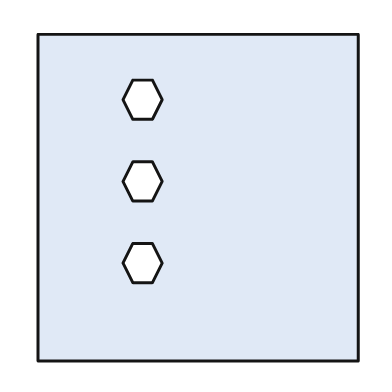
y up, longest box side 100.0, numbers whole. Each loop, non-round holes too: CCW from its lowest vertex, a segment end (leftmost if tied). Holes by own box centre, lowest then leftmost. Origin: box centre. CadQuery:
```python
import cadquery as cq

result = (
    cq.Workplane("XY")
    .moveTo(-49.0, -50.0)
    .lineTo(49.0, -50.0)
    .lineTo(49.0, 50.0)
    .lineTo(-49.0, 50.0)
    .close()
    .moveTo(-20.0, -26.0)
    .lineTo(-14.0, -26.0)
    .lineTo(-11.0, -20.0)
    .lineTo(-14.0, -14.0)
    .lineTo(-20.0, -14.0)
    .lineTo(-23.0, -20.0)
    .close()
    .moveTo(-20.0, -1.0)
    .lineTo(-14.0, -1.0)
    .lineTo(-11.0, 5.0)
    .lineTo(-14.0, 11.0)
    .lineTo(-20.0, 11.0)
    .lineTo(-23.0, 5.0)
    .close()
    .moveTo(-20.0, 24.0)
    .lineTo(-14.0, 24.0)
    .lineTo(-11.0, 30.0)
    .lineTo(-14.0, 36.0)
    .lineTo(-20.0, 36.0)
    .lineTo(-23.0, 30.0)
    .close()
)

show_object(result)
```